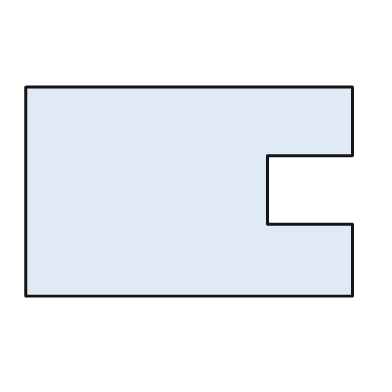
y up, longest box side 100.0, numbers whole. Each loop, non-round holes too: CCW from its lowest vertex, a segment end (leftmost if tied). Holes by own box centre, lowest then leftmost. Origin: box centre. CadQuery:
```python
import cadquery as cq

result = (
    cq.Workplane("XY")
    .moveTo(-50.0, -32.0)
    .lineTo(50.0, -32.0)
    .lineTo(50.0, -10.0)
    .lineTo(24.0, -10.0)
    .lineTo(24.0, 11.0)
    .lineTo(50.0, 11.0)
    .lineTo(50.0, 32.0)
    .lineTo(-50.0, 32.0)
    .close()
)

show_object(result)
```